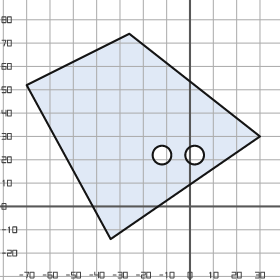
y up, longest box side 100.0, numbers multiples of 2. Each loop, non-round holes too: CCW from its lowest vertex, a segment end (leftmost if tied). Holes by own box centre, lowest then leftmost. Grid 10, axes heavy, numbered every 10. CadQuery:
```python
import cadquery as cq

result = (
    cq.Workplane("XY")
    .moveTo(-34.0, -14.0)
    .lineTo(30.0, 30.0)
    .lineTo(-26.0, 74.0)
    .lineTo(-70.0, 52.0)
    .close()
    .moveTo(-12.0, 22.0)
    .circle(4.0)
    .moveTo(2.0, 22.0)
    .circle(4.0)
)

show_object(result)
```